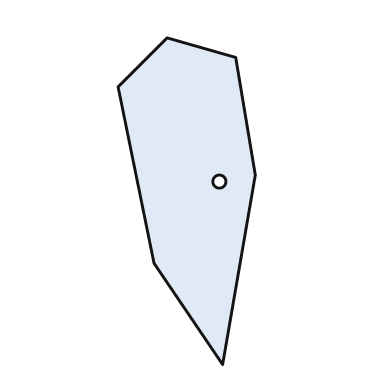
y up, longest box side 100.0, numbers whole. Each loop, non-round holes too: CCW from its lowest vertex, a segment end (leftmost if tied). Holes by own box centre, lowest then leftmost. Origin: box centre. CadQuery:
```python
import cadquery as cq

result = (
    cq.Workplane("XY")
    .moveTo(11.0, -50.0)
    .lineTo(21.0, 8.0)
    .lineTo(15.0, 44.0)
    .lineTo(-6.0, 50.0)
    .lineTo(-21.0, 35.0)
    .lineTo(-10.0, -19.0)
    .close()
    .moveTo(10.0, 6.0)
    .circle(2.0)
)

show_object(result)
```